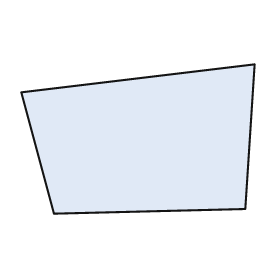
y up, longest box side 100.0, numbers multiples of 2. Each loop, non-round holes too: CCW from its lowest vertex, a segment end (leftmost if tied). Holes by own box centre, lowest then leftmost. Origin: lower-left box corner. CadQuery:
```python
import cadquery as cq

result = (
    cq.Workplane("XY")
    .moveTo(14.0, 0.0)
    .lineTo(96.0, 2.0)
    .lineTo(100.0, 64.0)
    .lineTo(0.0, 52.0)
    .close()
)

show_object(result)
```